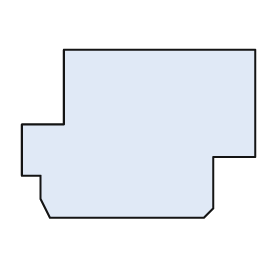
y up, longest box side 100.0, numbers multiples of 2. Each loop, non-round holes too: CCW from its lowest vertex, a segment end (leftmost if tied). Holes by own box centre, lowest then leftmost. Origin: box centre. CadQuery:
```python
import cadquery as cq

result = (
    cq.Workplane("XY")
    .moveTo(-38.0, -36.0)
    .lineTo(28.0, -36.0)
    .lineTo(32.0, -32.0)
    .lineTo(32.0, -10.0)
    .lineTo(50.0, -10.0)
    .lineTo(50.0, 36.0)
    .lineTo(-32.0, 36.0)
    .lineTo(-32.0, 4.0)
    .lineTo(-50.0, 4.0)
    .lineTo(-50.0, -18.0)
    .lineTo(-42.0, -18.0)
    .lineTo(-42.0, -28.0)
    .close()
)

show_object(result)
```